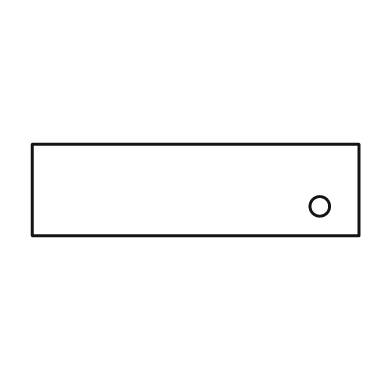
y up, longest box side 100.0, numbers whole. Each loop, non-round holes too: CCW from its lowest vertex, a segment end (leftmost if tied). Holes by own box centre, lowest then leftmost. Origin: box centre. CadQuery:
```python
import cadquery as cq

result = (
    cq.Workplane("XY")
    .moveTo(-50.0, -14.0)
    .lineTo(50.0, -14.0)
    .lineTo(50.0, 14.0)
    .lineTo(-50.0, 14.0)
    .close()
    .moveTo(38.0, -5.0)
    .circle(3.0)
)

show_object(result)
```